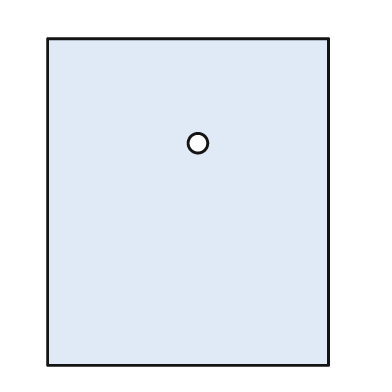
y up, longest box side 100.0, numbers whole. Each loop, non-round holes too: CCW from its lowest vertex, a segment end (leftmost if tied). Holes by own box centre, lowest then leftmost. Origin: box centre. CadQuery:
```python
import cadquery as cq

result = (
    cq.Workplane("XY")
    .moveTo(-43.0, -50.0)
    .lineTo(43.0, -50.0)
    .lineTo(43.0, 50.0)
    .lineTo(-43.0, 50.0)
    .close()
    .moveTo(3.0, 18.0)
    .circle(3.0)
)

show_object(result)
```